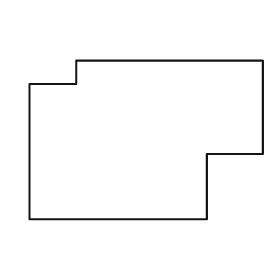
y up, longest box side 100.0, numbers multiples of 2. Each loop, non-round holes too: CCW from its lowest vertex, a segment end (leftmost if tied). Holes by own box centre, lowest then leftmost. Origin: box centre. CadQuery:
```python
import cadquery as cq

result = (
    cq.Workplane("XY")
    .moveTo(-50.0, -34.0)
    .lineTo(26.0, -34.0)
    .lineTo(26.0, -6.0)
    .lineTo(50.0, -6.0)
    .lineTo(50.0, 34.0)
    .lineTo(-30.0, 34.0)
    .lineTo(-30.0, 24.0)
    .lineTo(-50.0, 24.0)
    .close()
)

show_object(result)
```